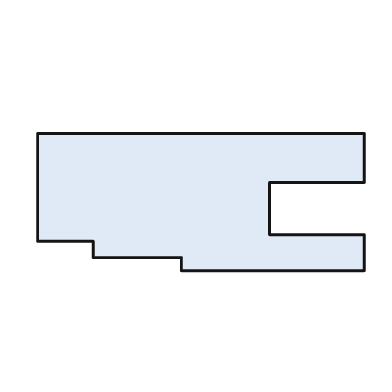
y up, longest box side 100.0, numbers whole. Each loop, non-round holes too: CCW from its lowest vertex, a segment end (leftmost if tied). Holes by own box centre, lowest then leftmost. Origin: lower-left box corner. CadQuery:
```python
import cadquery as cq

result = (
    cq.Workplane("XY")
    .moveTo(44.0, 0.0)
    .lineTo(100.0, 0.0)
    .lineTo(100.0, 11.0)
    .lineTo(71.0, 11.0)
    .lineTo(71.0, 27.0)
    .lineTo(100.0, 27.0)
    .lineTo(100.0, 42.0)
    .lineTo(0.0, 42.0)
    .lineTo(0.0, 9.0)
    .lineTo(17.0, 9.0)
    .lineTo(17.0, 4.0)
    .lineTo(44.0, 4.0)
    .close()
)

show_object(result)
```